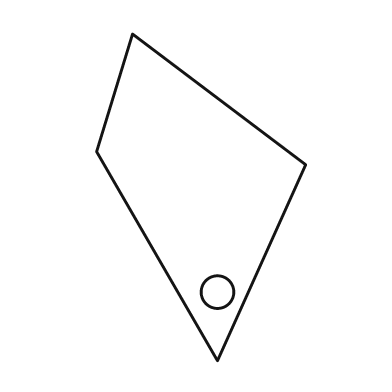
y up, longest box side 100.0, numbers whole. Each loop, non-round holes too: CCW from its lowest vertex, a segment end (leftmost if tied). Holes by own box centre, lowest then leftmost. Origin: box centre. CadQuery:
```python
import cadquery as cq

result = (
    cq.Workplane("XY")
    .moveTo(5.0, -50.0)
    .lineTo(32.0, 10.0)
    .lineTo(-21.0, 50.0)
    .lineTo(-32.0, 14.0)
    .close()
    .moveTo(5.0, -29.0)
    .circle(5.0)
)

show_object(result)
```